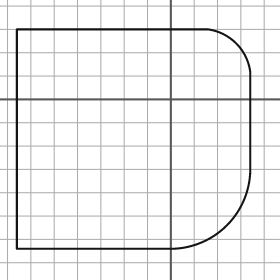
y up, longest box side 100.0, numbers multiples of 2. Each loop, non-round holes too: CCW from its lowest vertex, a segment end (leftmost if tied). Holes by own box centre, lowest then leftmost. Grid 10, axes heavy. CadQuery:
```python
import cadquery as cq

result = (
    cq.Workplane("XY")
    .moveTo(-66.0, -64.0)
    .lineTo(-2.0, -64.0)
    .threePointArc((24.0, -54.0), (34.0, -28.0))
    .lineTo(34.0, 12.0)
    .threePointArc((28.0, 24.0), (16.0, 30.0))
    .lineTo(-66.0, 30.0)
    .close()
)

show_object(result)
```